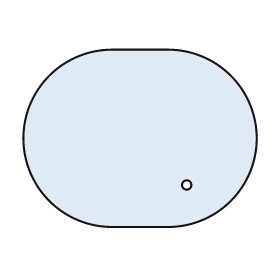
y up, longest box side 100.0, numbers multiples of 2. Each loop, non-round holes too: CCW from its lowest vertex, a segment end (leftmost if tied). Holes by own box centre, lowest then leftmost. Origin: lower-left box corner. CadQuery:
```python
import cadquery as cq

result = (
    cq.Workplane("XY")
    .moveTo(38.0, 0.0)
    .lineTo(62.0, 0.0)
    .threePointArc((100.0, 38.0), (62.0, 76.0))
    .lineTo(38.0, 76.0)
    .threePointArc((0.0, 38.0), (38.0, 0.0))
    .close()
    .moveTo(70.0, 18.0)
    .circle(2.0)
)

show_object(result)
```